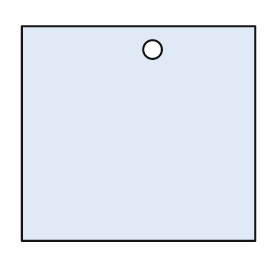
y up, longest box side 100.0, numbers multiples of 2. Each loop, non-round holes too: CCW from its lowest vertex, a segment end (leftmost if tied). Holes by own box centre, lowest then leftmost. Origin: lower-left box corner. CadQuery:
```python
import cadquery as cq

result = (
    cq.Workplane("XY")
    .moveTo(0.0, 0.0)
    .lineTo(100.0, 0.0)
    .lineTo(100.0, 92.0)
    .lineTo(0.0, 92.0)
    .close()
    .moveTo(56.0, 82.0)
    .circle(4.0)
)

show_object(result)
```